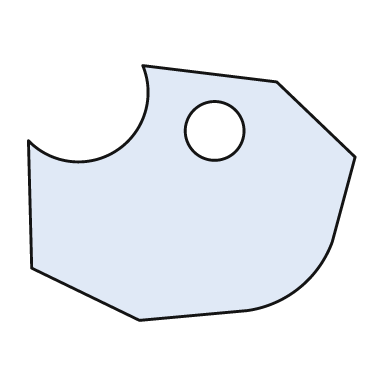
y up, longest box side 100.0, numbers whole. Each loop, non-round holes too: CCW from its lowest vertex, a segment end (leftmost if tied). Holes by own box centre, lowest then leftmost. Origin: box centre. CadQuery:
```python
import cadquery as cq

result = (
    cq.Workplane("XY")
    .moveTo(-16.0, -39.0)
    .lineTo(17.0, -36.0)
    .threePointArc((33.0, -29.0), (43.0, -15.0))
    .lineTo(50.0, 11.0)
    .lineTo(26.0, 34.0)
    .lineTo(-15.0, 39.0)
    .threePointArc((-23.0, 13.0), (-50.0, 16.0))
    .lineTo(-49.0, -23.0)
    .close()
    .moveTo(7.0, 19.0)
    .circle(9.0)
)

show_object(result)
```